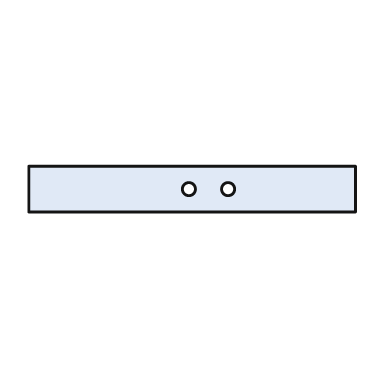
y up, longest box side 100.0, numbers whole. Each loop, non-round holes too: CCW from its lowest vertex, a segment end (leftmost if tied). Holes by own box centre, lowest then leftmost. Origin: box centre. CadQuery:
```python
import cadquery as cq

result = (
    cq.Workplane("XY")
    .moveTo(-50.0, -7.0)
    .lineTo(50.0, -7.0)
    .lineTo(50.0, 7.0)
    .lineTo(-50.0, 7.0)
    .close()
    .moveTo(-1.0, 0.0)
    .circle(2.0)
    .moveTo(11.0, 0.0)
    .circle(2.0)
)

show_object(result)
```